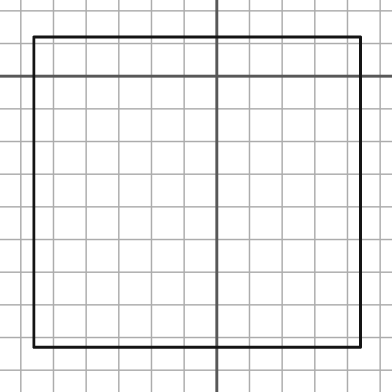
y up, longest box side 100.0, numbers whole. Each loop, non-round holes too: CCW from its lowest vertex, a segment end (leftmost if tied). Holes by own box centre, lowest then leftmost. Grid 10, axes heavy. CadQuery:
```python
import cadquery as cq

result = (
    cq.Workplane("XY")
    .moveTo(-56.0, -83.0)
    .lineTo(44.0, -83.0)
    .lineTo(44.0, 12.0)
    .lineTo(-56.0, 12.0)
    .close()
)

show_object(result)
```